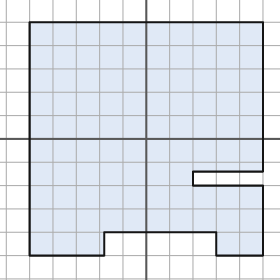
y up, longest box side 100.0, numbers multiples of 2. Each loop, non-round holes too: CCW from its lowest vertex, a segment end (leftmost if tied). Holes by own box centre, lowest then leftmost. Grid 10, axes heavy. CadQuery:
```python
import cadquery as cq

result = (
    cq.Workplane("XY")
    .moveTo(-50.0, -50.0)
    .lineTo(-18.0, -50.0)
    .lineTo(-18.0, -40.0)
    .lineTo(30.0, -40.0)
    .lineTo(30.0, -50.0)
    .lineTo(50.0, -50.0)
    .lineTo(50.0, -20.0)
    .lineTo(20.0, -20.0)
    .lineTo(20.0, -14.0)
    .lineTo(50.0, -14.0)
    .lineTo(50.0, 50.0)
    .lineTo(-50.0, 50.0)
    .close()
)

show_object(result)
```